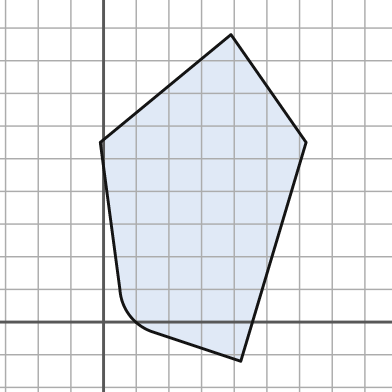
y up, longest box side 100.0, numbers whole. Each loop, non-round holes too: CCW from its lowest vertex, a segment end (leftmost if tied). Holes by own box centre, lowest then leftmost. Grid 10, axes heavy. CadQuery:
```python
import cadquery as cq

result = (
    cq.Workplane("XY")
    .moveTo(42.0, -12.0)
    .lineTo(62.0, 55.0)
    .lineTo(39.0, 88.0)
    .lineTo(-1.0, 55.0)
    .lineTo(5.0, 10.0)
    .threePointArc((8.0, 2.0), (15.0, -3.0))
    .close()
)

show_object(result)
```